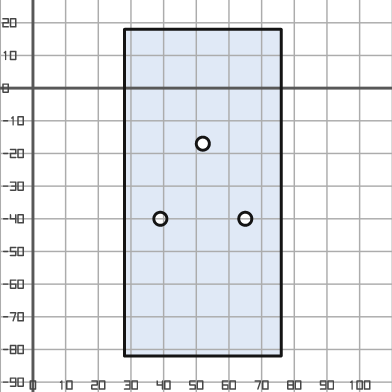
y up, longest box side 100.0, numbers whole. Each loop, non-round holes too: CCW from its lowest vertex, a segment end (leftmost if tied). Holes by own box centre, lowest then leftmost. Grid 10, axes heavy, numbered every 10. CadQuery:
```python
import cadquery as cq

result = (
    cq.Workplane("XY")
    .moveTo(28.0, -82.0)
    .lineTo(76.0, -82.0)
    .lineTo(76.0, 18.0)
    .lineTo(28.0, 18.0)
    .close()
    .moveTo(39.0, -40.0)
    .circle(2.0)
    .moveTo(65.0, -40.0)
    .circle(2.0)
    .moveTo(52.0, -17.0)
    .circle(2.0)
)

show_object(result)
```